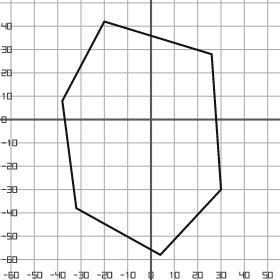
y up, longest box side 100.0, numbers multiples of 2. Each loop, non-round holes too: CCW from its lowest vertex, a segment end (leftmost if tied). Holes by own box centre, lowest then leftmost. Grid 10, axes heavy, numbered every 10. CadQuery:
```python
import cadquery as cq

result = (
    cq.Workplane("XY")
    .moveTo(4.0, -58.0)
    .lineTo(30.0, -30.0)
    .lineTo(26.0, 28.0)
    .lineTo(-20.0, 42.0)
    .lineTo(-38.0, 8.0)
    .lineTo(-32.0, -38.0)
    .close()
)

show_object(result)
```